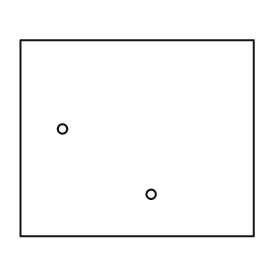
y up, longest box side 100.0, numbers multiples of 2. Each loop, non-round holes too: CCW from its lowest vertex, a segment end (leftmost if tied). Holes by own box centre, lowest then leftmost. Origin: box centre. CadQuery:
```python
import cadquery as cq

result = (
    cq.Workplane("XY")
    .moveTo(-50.0, -42.0)
    .lineTo(50.0, -42.0)
    .lineTo(50.0, 42.0)
    .lineTo(-50.0, 42.0)
    .close()
    .moveTo(6.0, -24.0)
    .circle(2.0)
    .moveTo(-32.0, 4.0)
    .circle(2.0)
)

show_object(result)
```